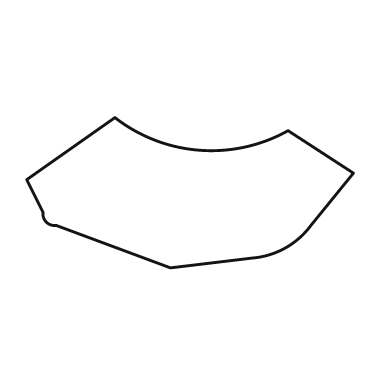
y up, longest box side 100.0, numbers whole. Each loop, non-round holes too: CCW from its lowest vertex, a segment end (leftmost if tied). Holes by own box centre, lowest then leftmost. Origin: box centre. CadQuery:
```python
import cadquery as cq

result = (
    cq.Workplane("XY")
    .moveTo(-6.0, -23.0)
    .lineTo(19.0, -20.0)
    .threePointArc((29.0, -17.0), (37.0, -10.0))
    .lineTo(50.0, 6.0)
    .lineTo(30.0, 19.0)
    .threePointArc((3.0, 13.0), (-23.0, 23.0))
    .lineTo(-50.0, 4.0)
    .lineTo(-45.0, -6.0)
    .threePointArc((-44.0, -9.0), (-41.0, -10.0))
    .close()
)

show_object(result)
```